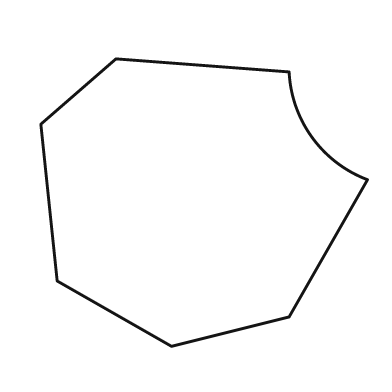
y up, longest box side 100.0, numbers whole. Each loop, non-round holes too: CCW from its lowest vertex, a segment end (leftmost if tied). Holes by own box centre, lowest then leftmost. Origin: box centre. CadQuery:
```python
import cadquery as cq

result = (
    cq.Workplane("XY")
    .moveTo(-10.0, -44.0)
    .lineTo(26.0, -35.0)
    .lineTo(50.0, 7.0)
    .threePointArc((33.0, 20.0), (26.0, 40.0))
    .lineTo(-27.0, 44.0)
    .lineTo(-50.0, 24.0)
    .lineTo(-45.0, -24.0)
    .close()
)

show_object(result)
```